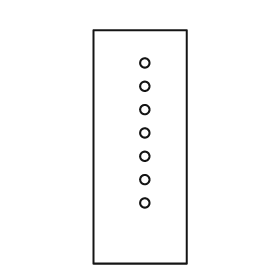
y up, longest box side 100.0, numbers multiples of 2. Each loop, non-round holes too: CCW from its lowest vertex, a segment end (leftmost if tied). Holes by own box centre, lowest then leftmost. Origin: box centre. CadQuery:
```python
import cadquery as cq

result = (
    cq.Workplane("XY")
    .moveTo(-20.0, -50.0)
    .lineTo(20.0, -50.0)
    .lineTo(20.0, 50.0)
    .lineTo(-20.0, 50.0)
    .close()
    .moveTo(2.0, -24.0)
    .circle(2.0)
    .moveTo(2.0, -14.0)
    .circle(2.0)
    .moveTo(2.0, -4.0)
    .circle(2.0)
    .moveTo(2.0, 6.0)
    .circle(2.0)
    .moveTo(2.0, 16.0)
    .circle(2.0)
    .moveTo(2.0, 26.0)
    .circle(2.0)
    .moveTo(2.0, 36.0)
    .circle(2.0)
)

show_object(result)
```